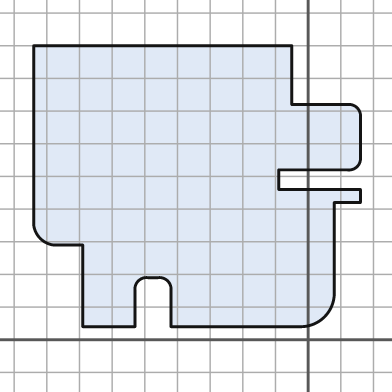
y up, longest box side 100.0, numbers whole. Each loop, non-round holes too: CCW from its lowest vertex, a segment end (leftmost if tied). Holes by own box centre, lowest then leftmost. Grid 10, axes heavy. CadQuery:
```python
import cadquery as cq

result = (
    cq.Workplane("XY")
    .moveTo(-69.0, 4.0)
    .lineTo(-53.0, 4.0)
    .lineTo(-53.0, 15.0)
    .threePointArc((-52.0, 18.0), (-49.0, 19.0))
    .lineTo(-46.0, 19.0)
    .threePointArc((-43.0, 18.0), (-42.0, 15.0))
    .lineTo(-42.0, 4.0)
    .lineTo(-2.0, 4.0)
    .threePointArc((5.0, 7.0), (8.0, 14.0))
    .lineTo(8.0, 42.0)
    .lineTo(16.0, 42.0)
    .lineTo(16.0, 46.0)
    .lineTo(-9.0, 46.0)
    .lineTo(-9.0, 52.0)
    .lineTo(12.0, 52.0)
    .threePointArc((15.0, 53.0), (16.0, 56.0))
    .lineTo(16.0, 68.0)
    .threePointArc((15.0, 71.0), (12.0, 72.0))
    .lineTo(-5.0, 72.0)
    .lineTo(-5.0, 90.0)
    .lineTo(-84.0, 90.0)
    .lineTo(-84.0, 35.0)
    .threePointArc((-82.0, 31.0), (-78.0, 29.0))
    .lineTo(-69.0, 29.0)
    .close()
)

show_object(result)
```